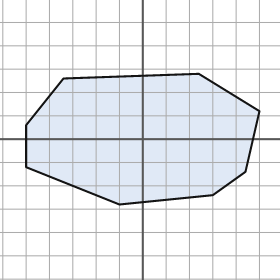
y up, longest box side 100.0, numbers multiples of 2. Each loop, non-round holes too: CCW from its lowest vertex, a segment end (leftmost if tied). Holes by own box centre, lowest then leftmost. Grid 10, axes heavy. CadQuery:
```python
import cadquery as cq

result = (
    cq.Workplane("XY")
    .moveTo(-10.0, -28.0)
    .lineTo(30.0, -24.0)
    .lineTo(44.0, -14.0)
    .lineTo(50.0, 12.0)
    .lineTo(24.0, 28.0)
    .lineTo(-34.0, 26.0)
    .lineTo(-50.0, 6.0)
    .lineTo(-50.0, -12.0)
    .close()
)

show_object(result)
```